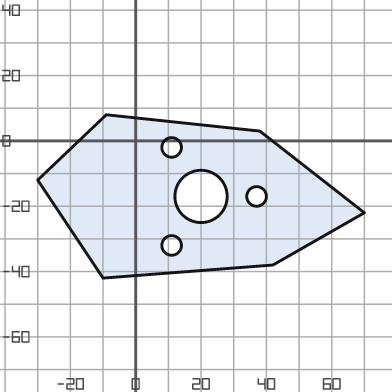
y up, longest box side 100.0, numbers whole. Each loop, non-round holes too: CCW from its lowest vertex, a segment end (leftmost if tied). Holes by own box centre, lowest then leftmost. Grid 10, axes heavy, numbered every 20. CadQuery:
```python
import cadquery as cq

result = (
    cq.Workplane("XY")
    .moveTo(-10.0, -42.0)
    .lineTo(42.0, -38.0)
    .lineTo(70.0, -22.0)
    .lineTo(38.0, 3.0)
    .lineTo(-9.0, 8.0)
    .lineTo(-30.0, -12.0)
    .close()
    .moveTo(11.0, -32.0)
    .circle(3.0)
    .moveTo(20.0, -17.0)
    .circle(8.0)
    .moveTo(37.0, -17.0)
    .circle(3.0)
    .moveTo(11.0, -2.0)
    .circle(3.0)
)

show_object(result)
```